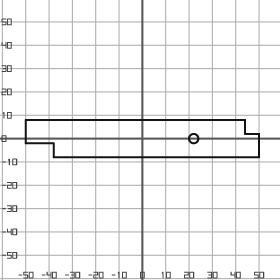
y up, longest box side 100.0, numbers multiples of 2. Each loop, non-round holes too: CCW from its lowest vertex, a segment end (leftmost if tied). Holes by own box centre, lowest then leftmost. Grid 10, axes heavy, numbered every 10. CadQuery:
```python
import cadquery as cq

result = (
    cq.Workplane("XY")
    .moveTo(-38.0, -8.0)
    .lineTo(50.0, -8.0)
    .lineTo(50.0, 2.0)
    .lineTo(44.0, 2.0)
    .lineTo(44.0, 8.0)
    .lineTo(-50.0, 8.0)
    .lineTo(-50.0, -2.0)
    .lineTo(-38.0, -2.0)
    .close()
    .moveTo(22.0, 0.0)
    .circle(2.0)
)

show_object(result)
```